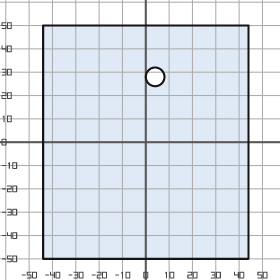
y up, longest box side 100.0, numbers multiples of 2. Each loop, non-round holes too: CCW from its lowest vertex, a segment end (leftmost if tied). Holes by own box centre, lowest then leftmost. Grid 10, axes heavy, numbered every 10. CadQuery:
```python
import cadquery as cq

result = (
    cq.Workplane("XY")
    .moveTo(-44.0, -50.0)
    .lineTo(44.0, -50.0)
    .lineTo(44.0, 50.0)
    .lineTo(-44.0, 50.0)
    .close()
    .moveTo(4.0, 28.0)
    .circle(4.0)
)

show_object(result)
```